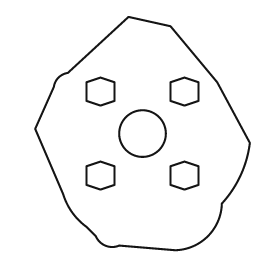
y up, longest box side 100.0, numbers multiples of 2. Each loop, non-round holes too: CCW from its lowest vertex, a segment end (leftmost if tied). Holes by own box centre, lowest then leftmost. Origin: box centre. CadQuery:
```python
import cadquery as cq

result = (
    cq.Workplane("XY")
    .moveTo(14.0, -50.0)
    .threePointArc((28.0, -44.0), (34.0, -30.0))
    .threePointArc((42.0, -18.0), (46.0, -4.0))
    .lineTo(32.0, 22.0)
    .lineTo(12.0, 46.0)
    .lineTo(-6.0, 50.0)
    .lineTo(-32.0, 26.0)
    .threePointArc((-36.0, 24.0), (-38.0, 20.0))
    .lineTo(-46.0, 2.0)
    .lineTo(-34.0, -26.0)
    .threePointArc((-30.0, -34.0), (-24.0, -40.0))
    .lineTo(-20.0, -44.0)
    .threePointArc((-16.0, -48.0), (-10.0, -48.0))
    .close()
    .moveTo(-18.0, -24.0)
    .lineTo(-12.0, -22.0)
    .lineTo(-12.0, -14.0)
    .lineTo(-18.0, -12.0)
    .lineTo(-24.0, -14.0)
    .lineTo(-24.0, -22.0)
    .close()
    .moveTo(18.0, -24.0)
    .lineTo(24.0, -22.0)
    .lineTo(24.0, -14.0)
    .lineTo(18.0, -12.0)
    .lineTo(12.0, -14.0)
    .lineTo(12.0, -22.0)
    .close()
    .moveTo(0.0, 0.0)
    .circle(10.0)
    .moveTo(-18.0, 12.0)
    .lineTo(-12.0, 14.0)
    .lineTo(-12.0, 22.0)
    .lineTo(-18.0, 24.0)
    .lineTo(-24.0, 22.0)
    .lineTo(-24.0, 14.0)
    .close()
    .moveTo(18.0, 12.0)
    .lineTo(24.0, 14.0)
    .lineTo(24.0, 22.0)
    .lineTo(18.0, 24.0)
    .lineTo(12.0, 22.0)
    .lineTo(12.0, 14.0)
    .close()
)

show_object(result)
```